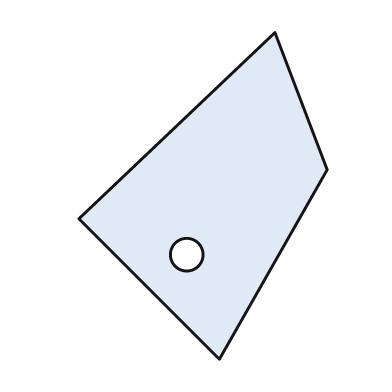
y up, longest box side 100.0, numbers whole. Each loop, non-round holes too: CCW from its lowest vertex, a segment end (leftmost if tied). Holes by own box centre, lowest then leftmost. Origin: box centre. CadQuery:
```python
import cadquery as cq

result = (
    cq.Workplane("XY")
    .moveTo(5.0, -50.0)
    .lineTo(38.0, 8.0)
    .lineTo(22.0, 50.0)
    .lineTo(-38.0, -7.0)
    .close()
    .moveTo(-5.0, -18.0)
    .circle(5.0)
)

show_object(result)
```